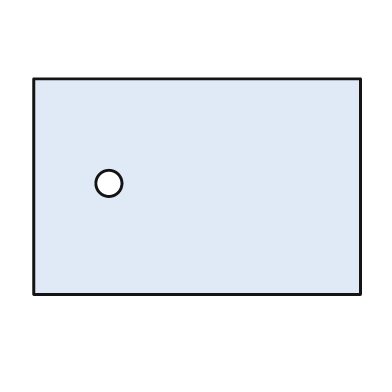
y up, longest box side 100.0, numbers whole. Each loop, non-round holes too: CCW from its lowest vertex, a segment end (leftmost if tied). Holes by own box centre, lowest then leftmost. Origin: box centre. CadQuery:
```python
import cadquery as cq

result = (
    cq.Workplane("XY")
    .moveTo(-50.0, -33.0)
    .lineTo(50.0, -33.0)
    .lineTo(50.0, 33.0)
    .lineTo(-50.0, 33.0)
    .close()
    .moveTo(-27.0, 1.0)
    .circle(4.0)
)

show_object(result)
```